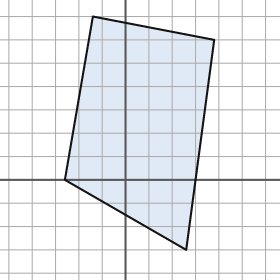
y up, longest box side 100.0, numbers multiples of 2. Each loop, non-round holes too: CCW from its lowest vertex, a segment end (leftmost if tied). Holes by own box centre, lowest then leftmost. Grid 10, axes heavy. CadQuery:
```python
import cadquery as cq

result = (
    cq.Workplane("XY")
    .moveTo(26.0, -30.0)
    .lineTo(38.0, 60.0)
    .lineTo(-14.0, 70.0)
    .lineTo(-26.0, 0.0)
    .close()
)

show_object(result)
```